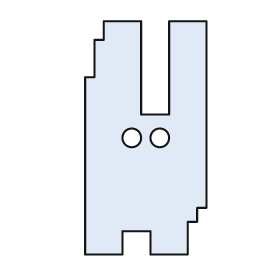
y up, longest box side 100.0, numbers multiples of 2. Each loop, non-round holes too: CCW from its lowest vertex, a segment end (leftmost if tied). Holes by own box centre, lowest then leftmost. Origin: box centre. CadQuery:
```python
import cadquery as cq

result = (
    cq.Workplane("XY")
    .moveTo(-26.0, -50.0)
    .lineTo(-10.0, -50.0)
    .lineTo(-10.0, -40.0)
    .lineTo(2.0, -40.0)
    .lineTo(2.0, -50.0)
    .lineTo(18.0, -50.0)
    .lineTo(18.0, -36.0)
    .lineTo(22.0, -36.0)
    .lineTo(22.0, -30.0)
    .lineTo(26.0, -30.0)
    .lineTo(26.0, 50.0)
    .lineTo(10.0, 50.0)
    .lineTo(10.0, 10.0)
    .lineTo(-2.0, 10.0)
    .lineTo(-2.0, 50.0)
    .lineTo(-18.0, 50.0)
    .lineTo(-18.0, 42.0)
    .lineTo(-22.0, 42.0)
    .lineTo(-22.0, 26.0)
    .lineTo(-26.0, 26.0)
    .close()
    .moveTo(-6.0, 0.0)
    .circle(4.0)
    .moveTo(6.0, 0.0)
    .circle(4.0)
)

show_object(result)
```